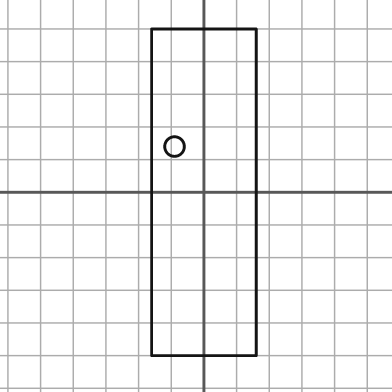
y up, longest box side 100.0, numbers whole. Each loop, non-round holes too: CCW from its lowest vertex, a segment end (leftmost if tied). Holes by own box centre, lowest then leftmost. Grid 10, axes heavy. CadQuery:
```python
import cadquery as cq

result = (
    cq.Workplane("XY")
    .moveTo(-16.0, -50.0)
    .lineTo(16.0, -50.0)
    .lineTo(16.0, 50.0)
    .lineTo(-16.0, 50.0)
    .close()
    .moveTo(-9.0, 14.0)
    .circle(3.0)
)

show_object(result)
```